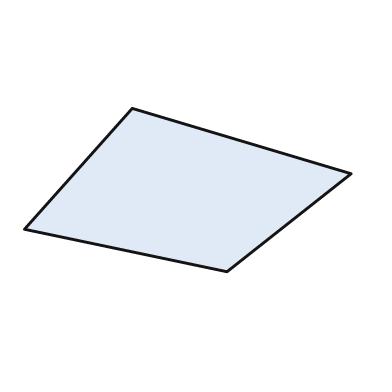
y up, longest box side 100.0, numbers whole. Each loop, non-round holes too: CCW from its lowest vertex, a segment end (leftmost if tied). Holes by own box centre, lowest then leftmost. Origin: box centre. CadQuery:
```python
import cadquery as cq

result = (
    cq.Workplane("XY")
    .moveTo(12.0, -25.0)
    .lineTo(50.0, 5.0)
    .lineTo(-17.0, 25.0)
    .lineTo(-50.0, -12.0)
    .close()
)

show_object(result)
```